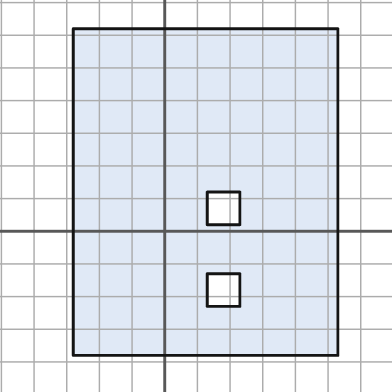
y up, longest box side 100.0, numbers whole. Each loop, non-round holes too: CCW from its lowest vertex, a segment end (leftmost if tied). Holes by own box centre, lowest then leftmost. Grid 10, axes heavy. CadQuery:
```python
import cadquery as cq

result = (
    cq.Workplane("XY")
    .moveTo(-28.0, -38.0)
    .lineTo(53.0, -38.0)
    .lineTo(53.0, 62.0)
    .lineTo(-28.0, 62.0)
    .close()
    .moveTo(13.0, -23.0)
    .lineTo(23.0, -23.0)
    .lineTo(23.0, -13.0)
    .lineTo(13.0, -13.0)
    .close()
    .moveTo(13.0, 2.0)
    .lineTo(23.0, 2.0)
    .lineTo(23.0, 12.0)
    .lineTo(13.0, 12.0)
    .close()
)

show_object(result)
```